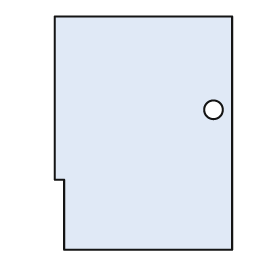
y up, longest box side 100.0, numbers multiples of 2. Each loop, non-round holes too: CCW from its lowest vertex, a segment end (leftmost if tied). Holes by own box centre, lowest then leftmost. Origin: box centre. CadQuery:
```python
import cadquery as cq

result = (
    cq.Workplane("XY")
    .moveTo(-34.0, -50.0)
    .lineTo(38.0, -50.0)
    .lineTo(38.0, 50.0)
    .lineTo(-38.0, 50.0)
    .lineTo(-38.0, -20.0)
    .lineTo(-34.0, -20.0)
    .close()
    .moveTo(30.0, 10.0)
    .circle(4.0)
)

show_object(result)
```